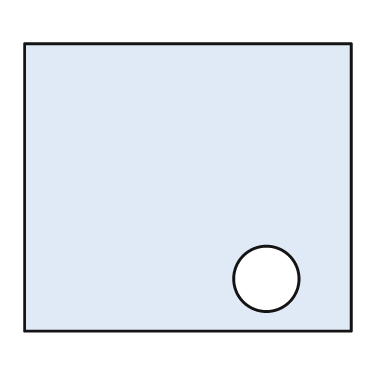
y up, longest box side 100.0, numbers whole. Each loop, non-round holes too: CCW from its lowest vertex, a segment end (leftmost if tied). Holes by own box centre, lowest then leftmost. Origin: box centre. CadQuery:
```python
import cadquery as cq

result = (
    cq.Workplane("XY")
    .moveTo(-50.0, -44.0)
    .lineTo(50.0, -44.0)
    .lineTo(50.0, 44.0)
    .lineTo(-50.0, 44.0)
    .close()
    .moveTo(24.0, -28.0)
    .circle(10.0)
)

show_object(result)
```